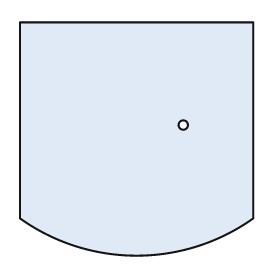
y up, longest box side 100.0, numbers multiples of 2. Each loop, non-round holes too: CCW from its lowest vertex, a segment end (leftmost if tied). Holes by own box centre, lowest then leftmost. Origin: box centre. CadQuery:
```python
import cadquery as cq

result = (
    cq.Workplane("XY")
    .moveTo(-50.0, -34.0)
    .threePointArc((0.0, -50.0), (50.0, -34.0))
    .lineTo(50.0, 50.0)
    .lineTo(-50.0, 50.0)
    .close()
    .moveTo(20.0, 6.0)
    .circle(2.0)
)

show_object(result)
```